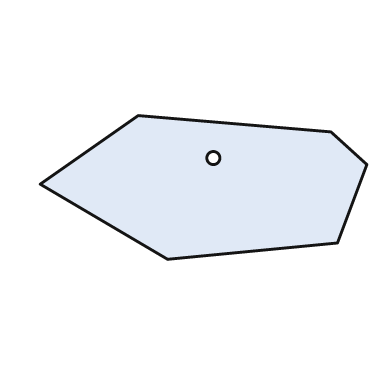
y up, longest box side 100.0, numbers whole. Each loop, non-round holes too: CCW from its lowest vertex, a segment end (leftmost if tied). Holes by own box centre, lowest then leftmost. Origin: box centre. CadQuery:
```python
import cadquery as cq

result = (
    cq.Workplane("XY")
    .moveTo(-11.0, -22.0)
    .lineTo(41.0, -17.0)
    .lineTo(50.0, 7.0)
    .lineTo(39.0, 17.0)
    .lineTo(-20.0, 22.0)
    .lineTo(-50.0, 1.0)
    .close()
    .moveTo(3.0, 9.0)
    .circle(2.0)
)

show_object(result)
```